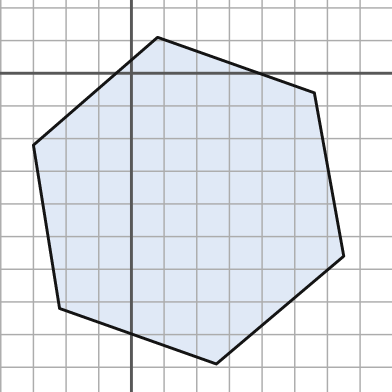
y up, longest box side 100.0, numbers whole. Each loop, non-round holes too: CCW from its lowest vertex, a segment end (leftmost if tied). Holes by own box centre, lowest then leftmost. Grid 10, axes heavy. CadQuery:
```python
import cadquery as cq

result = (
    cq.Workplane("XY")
    .moveTo(26.0, -89.0)
    .lineTo(65.0, -56.0)
    .lineTo(56.0, -6.0)
    .lineTo(8.0, 11.0)
    .lineTo(-30.0, -22.0)
    .lineTo(-22.0, -72.0)
    .close()
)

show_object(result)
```